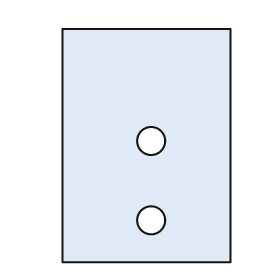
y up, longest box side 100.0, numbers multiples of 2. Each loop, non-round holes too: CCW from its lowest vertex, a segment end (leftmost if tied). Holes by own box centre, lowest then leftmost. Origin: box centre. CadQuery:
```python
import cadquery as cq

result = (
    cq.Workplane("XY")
    .moveTo(-36.0, -50.0)
    .lineTo(36.0, -50.0)
    .lineTo(36.0, 50.0)
    .lineTo(-36.0, 50.0)
    .close()
    .moveTo(2.0, -32.0)
    .circle(6.0)
    .moveTo(2.0, 2.0)
    .circle(6.0)
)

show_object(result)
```